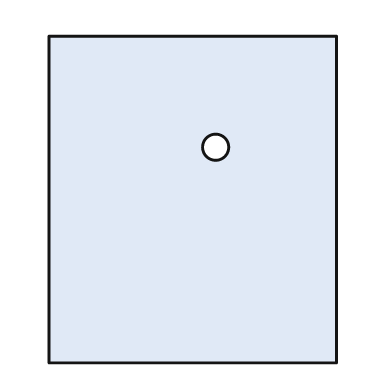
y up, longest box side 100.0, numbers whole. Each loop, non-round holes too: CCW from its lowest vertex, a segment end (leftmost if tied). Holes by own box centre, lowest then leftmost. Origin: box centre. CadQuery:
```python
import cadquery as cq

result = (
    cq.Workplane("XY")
    .moveTo(-44.0, -50.0)
    .lineTo(44.0, -50.0)
    .lineTo(44.0, 50.0)
    .lineTo(-44.0, 50.0)
    .close()
    .moveTo(7.0, 16.0)
    .circle(4.0)
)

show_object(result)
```